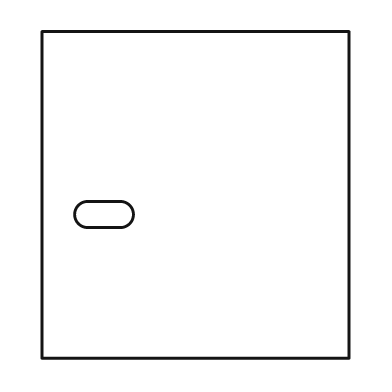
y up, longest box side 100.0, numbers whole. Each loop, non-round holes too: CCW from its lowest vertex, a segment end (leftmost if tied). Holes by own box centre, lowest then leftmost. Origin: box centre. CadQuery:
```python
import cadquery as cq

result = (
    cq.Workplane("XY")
    .moveTo(-47.0, -50.0)
    .lineTo(47.0, -50.0)
    .lineTo(47.0, 50.0)
    .lineTo(-47.0, 50.0)
    .close()
    .moveTo(-33.0, -10.0)
    .lineTo(-23.0, -10.0)
    .threePointArc((-19.0, -6.0), (-23.0, -2.0))
    .lineTo(-33.0, -2.0)
    .threePointArc((-37.0, -6.0), (-33.0, -10.0))
    .close()
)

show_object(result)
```